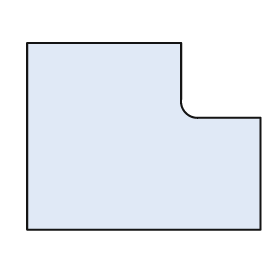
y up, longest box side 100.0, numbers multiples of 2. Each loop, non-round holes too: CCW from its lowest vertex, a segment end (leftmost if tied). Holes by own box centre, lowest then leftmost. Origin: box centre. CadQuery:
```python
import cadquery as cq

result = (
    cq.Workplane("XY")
    .moveTo(-50.0, -40.0)
    .lineTo(50.0, -40.0)
    .lineTo(50.0, 8.0)
    .lineTo(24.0, 8.0)
    .threePointArc((18.0, 10.0), (16.0, 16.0))
    .lineTo(16.0, 40.0)
    .lineTo(-50.0, 40.0)
    .close()
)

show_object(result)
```